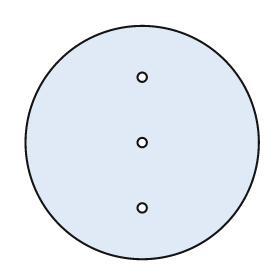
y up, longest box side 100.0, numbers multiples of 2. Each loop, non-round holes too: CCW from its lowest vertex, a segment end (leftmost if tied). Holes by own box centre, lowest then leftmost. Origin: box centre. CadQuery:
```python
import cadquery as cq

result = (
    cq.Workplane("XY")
    .moveTo(0.0, 0.0)
    .circle(50.0)
    .moveTo(0.0, -28.0)
    .circle(2.0)
    .moveTo(0.0, 0.0)
    .circle(2.0)
    .moveTo(0.0, 28.0)
    .circle(2.0)
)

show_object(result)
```